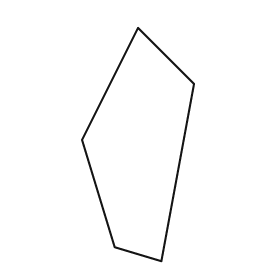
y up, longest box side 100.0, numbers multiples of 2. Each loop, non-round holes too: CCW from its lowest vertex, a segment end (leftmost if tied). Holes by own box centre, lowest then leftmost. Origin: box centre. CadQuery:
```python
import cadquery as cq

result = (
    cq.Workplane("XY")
    .moveTo(10.0, -50.0)
    .lineTo(24.0, 26.0)
    .lineTo(0.0, 50.0)
    .lineTo(-24.0, 2.0)
    .lineTo(-10.0, -44.0)
    .close()
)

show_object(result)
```